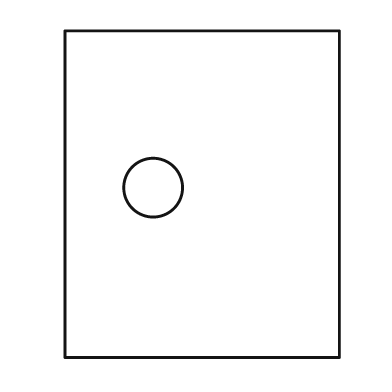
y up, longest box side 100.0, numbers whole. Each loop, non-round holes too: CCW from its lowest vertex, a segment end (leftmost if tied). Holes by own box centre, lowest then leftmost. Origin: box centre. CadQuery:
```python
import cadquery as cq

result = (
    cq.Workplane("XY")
    .moveTo(-42.0, -50.0)
    .lineTo(42.0, -50.0)
    .lineTo(42.0, 50.0)
    .lineTo(-42.0, 50.0)
    .close()
    .moveTo(-15.0, 2.0)
    .circle(9.0)
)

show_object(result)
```